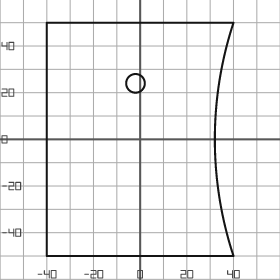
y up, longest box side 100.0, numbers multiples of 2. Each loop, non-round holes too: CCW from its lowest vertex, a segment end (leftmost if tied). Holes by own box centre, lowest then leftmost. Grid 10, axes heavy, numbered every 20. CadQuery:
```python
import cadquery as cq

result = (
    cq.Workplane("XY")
    .moveTo(-40.0, -50.0)
    .lineTo(40.0, -50.0)
    .threePointArc((32.0, 0.0), (40.0, 50.0))
    .lineTo(-40.0, 50.0)
    .close()
    .moveTo(-2.0, 24.0)
    .circle(4.0)
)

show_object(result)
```